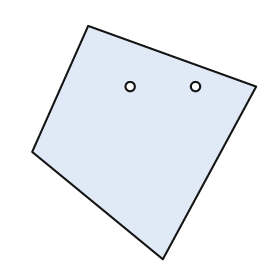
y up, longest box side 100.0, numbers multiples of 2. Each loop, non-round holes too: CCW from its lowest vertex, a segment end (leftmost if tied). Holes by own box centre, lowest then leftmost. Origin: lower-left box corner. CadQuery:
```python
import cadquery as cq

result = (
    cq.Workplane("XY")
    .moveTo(56.0, 0.0)
    .lineTo(96.0, 74.0)
    .lineTo(24.0, 100.0)
    .lineTo(0.0, 46.0)
    .close()
    .moveTo(42.0, 74.0)
    .circle(2.0)
    .moveTo(70.0, 74.0)
    .circle(2.0)
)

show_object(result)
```